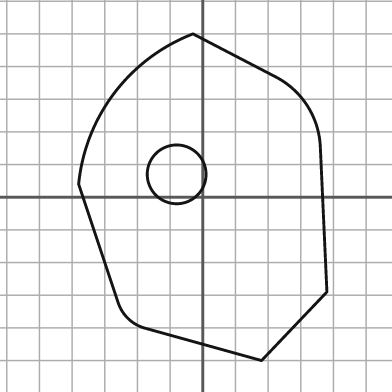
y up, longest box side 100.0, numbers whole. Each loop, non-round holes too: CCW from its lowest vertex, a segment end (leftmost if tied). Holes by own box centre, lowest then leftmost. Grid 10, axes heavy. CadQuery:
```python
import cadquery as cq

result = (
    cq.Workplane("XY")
    .moveTo(18.0, -50.0)
    .lineTo(38.0, -29.0)
    .lineTo(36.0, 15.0)
    .threePointArc((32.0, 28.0), (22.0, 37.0))
    .lineTo(-3.0, 50.0)
    .threePointArc((-27.0, 32.0), (-38.0, 4.0))
    .lineTo(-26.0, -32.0)
    .threePointArc((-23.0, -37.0), (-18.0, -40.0))
    .close()
    .moveTo(-8.0, 7.0)
    .circle(9.0)
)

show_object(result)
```